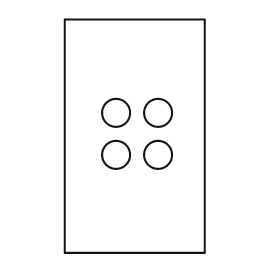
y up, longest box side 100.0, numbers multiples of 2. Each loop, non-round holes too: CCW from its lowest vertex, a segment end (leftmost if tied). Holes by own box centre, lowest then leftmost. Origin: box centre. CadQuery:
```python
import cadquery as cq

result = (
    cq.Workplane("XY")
    .moveTo(-30.0, -50.0)
    .lineTo(30.0, -50.0)
    .lineTo(30.0, 50.0)
    .lineTo(-30.0, 50.0)
    .close()
    .moveTo(-8.0, -8.0)
    .circle(6.0)
    .moveTo(10.0, -8.0)
    .circle(6.0)
    .moveTo(-8.0, 10.0)
    .circle(6.0)
    .moveTo(10.0, 10.0)
    .circle(6.0)
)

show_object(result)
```